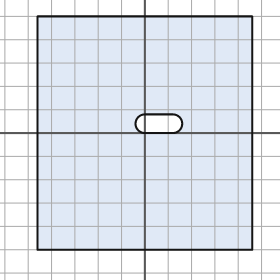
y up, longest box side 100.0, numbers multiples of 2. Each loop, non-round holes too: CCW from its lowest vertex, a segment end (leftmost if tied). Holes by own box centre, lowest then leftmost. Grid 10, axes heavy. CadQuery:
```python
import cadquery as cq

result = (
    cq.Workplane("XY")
    .moveTo(-46.0, -50.0)
    .lineTo(46.0, -50.0)
    .lineTo(46.0, 50.0)
    .lineTo(-46.0, 50.0)
    .close()
    .moveTo(0.0, 0.0)
    .lineTo(12.0, 0.0)
    .threePointArc((16.0, 4.0), (12.0, 8.0))
    .lineTo(0.0, 8.0)
    .threePointArc((-4.0, 4.0), (0.0, 0.0))
    .close()
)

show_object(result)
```